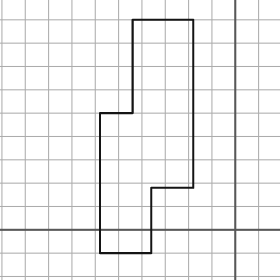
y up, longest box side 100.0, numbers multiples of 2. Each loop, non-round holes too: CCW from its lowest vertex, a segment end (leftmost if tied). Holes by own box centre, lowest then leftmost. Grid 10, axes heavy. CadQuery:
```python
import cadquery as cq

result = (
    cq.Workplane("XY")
    .moveTo(-58.0, -10.0)
    .lineTo(-36.0, -10.0)
    .lineTo(-36.0, 18.0)
    .lineTo(-18.0, 18.0)
    .lineTo(-18.0, 90.0)
    .lineTo(-44.0, 90.0)
    .lineTo(-44.0, 50.0)
    .lineTo(-58.0, 50.0)
    .close()
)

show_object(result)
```